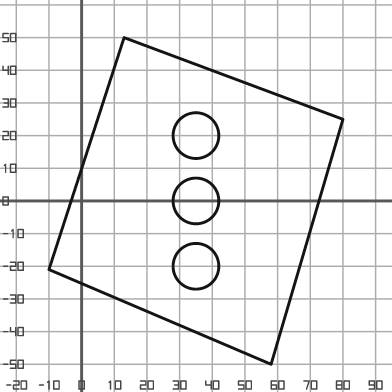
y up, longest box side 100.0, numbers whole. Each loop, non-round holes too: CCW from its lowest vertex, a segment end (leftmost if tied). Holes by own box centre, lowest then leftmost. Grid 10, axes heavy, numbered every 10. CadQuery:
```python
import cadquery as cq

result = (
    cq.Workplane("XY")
    .moveTo(58.0, -50.0)
    .lineTo(80.0, 25.0)
    .lineTo(13.0, 50.0)
    .lineTo(-10.0, -21.0)
    .close()
    .moveTo(35.0, -20.0)
    .circle(7.0)
    .moveTo(35.0, 0.0)
    .circle(7.0)
    .moveTo(35.0, 20.0)
    .circle(7.0)
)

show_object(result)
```